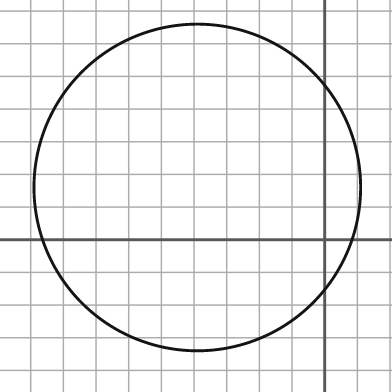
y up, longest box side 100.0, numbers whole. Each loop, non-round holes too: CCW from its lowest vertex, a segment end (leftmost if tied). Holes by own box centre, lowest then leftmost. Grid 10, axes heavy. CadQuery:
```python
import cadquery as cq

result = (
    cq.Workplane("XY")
    .moveTo(-39.0, 16.0)
    .circle(50.0)
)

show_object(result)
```